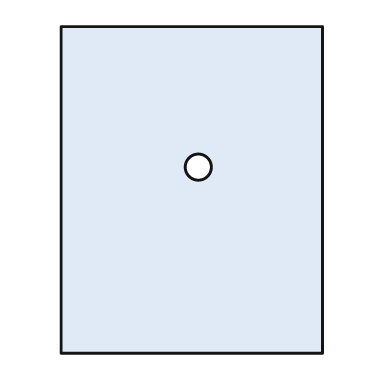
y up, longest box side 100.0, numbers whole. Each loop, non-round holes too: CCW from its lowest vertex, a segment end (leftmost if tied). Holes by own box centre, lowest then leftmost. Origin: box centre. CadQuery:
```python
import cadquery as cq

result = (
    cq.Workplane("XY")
    .moveTo(-40.0, -50.0)
    .lineTo(40.0, -50.0)
    .lineTo(40.0, 50.0)
    .lineTo(-40.0, 50.0)
    .close()
    .moveTo(2.0, 7.0)
    .circle(4.0)
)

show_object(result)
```